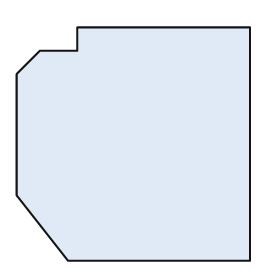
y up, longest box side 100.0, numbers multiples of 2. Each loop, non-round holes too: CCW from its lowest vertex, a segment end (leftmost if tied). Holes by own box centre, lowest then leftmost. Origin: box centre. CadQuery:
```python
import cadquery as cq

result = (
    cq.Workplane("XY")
    .moveTo(-28.0, -50.0)
    .lineTo(50.0, -50.0)
    .lineTo(50.0, 50.0)
    .lineTo(-24.0, 50.0)
    .lineTo(-24.0, 40.0)
    .lineTo(-40.0, 40.0)
    .lineTo(-50.0, 30.0)
    .lineTo(-50.0, -22.0)
    .close()
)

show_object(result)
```